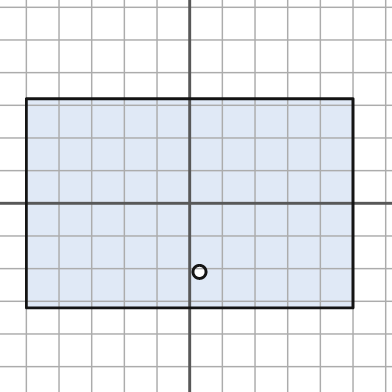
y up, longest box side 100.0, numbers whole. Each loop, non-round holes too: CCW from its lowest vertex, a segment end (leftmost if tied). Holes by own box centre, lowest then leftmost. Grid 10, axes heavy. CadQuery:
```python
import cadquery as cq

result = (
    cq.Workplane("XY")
    .moveTo(-50.0, -32.0)
    .lineTo(50.0, -32.0)
    .lineTo(50.0, 32.0)
    .lineTo(-50.0, 32.0)
    .close()
    .moveTo(3.0, -21.0)
    .circle(2.0)
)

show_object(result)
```